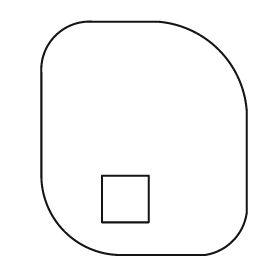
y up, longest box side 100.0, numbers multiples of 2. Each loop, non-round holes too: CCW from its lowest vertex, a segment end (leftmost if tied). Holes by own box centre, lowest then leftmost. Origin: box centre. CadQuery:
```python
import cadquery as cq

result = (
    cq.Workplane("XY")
    .moveTo(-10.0, -50.0)
    .lineTo(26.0, -50.0)
    .threePointArc((38.0, -44.0), (44.0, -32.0))
    .lineTo(44.0, 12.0)
    .threePointArc((32.0, 38.0), (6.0, 50.0))
    .lineTo(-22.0, 50.0)
    .threePointArc((-38.0, 44.0), (-44.0, 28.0))
    .lineTo(-44.0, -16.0)
    .threePointArc((-34.0, -40.0), (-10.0, -50.0))
    .close()
    .moveTo(-18.0, -36.0)
    .lineTo(2.0, -36.0)
    .lineTo(2.0, -16.0)
    .lineTo(-18.0, -16.0)
    .close()
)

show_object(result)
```